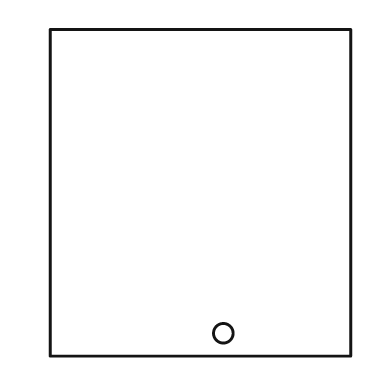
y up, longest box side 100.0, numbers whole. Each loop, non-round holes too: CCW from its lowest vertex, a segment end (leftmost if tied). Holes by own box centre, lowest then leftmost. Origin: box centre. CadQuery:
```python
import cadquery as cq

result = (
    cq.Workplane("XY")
    .moveTo(-46.0, -50.0)
    .lineTo(46.0, -50.0)
    .lineTo(46.0, 50.0)
    .lineTo(-46.0, 50.0)
    .close()
    .moveTo(7.0, -43.0)
    .circle(3.0)
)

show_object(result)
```